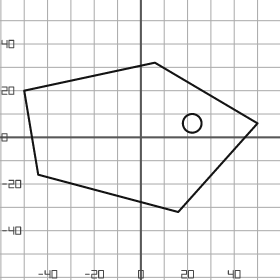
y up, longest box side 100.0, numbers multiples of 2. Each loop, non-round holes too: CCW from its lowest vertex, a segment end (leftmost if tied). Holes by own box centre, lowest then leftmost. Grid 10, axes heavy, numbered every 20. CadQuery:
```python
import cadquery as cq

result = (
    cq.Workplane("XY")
    .moveTo(16.0, -32.0)
    .lineTo(50.0, 6.0)
    .lineTo(6.0, 32.0)
    .lineTo(-50.0, 20.0)
    .lineTo(-44.0, -16.0)
    .close()
    .moveTo(22.0, 6.0)
    .circle(4.0)
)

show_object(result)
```